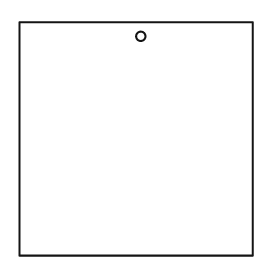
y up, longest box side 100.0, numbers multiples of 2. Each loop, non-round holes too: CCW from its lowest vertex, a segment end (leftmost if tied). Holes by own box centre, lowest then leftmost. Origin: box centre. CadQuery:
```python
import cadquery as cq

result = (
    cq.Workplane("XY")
    .moveTo(-50.0, -50.0)
    .lineTo(50.0, -50.0)
    .lineTo(50.0, 50.0)
    .lineTo(-50.0, 50.0)
    .close()
    .moveTo(2.0, 44.0)
    .circle(2.0)
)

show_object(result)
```